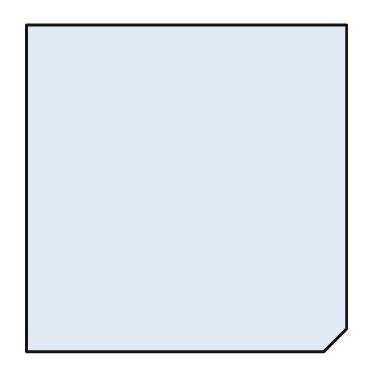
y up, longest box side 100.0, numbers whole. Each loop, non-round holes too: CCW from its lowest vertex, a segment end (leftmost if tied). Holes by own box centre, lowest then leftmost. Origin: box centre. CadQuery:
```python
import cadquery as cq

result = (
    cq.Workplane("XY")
    .moveTo(-49.0, -50.0)
    .lineTo(42.0, -50.0)
    .lineTo(49.0, -43.0)
    .lineTo(49.0, 50.0)
    .lineTo(-49.0, 50.0)
    .close()
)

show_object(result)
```